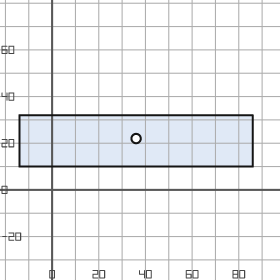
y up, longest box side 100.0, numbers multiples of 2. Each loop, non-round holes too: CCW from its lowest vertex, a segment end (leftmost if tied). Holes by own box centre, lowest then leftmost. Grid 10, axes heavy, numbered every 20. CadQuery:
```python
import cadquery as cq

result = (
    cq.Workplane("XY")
    .moveTo(-14.0, 10.0)
    .lineTo(86.0, 10.0)
    .lineTo(86.0, 32.0)
    .lineTo(-14.0, 32.0)
    .close()
    .moveTo(36.0, 22.0)
    .circle(2.0)
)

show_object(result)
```